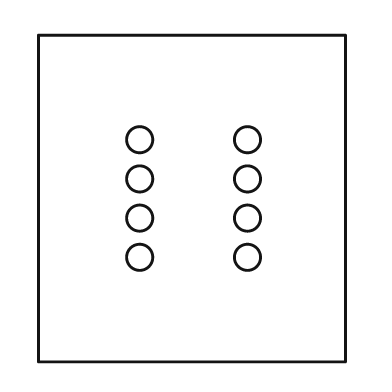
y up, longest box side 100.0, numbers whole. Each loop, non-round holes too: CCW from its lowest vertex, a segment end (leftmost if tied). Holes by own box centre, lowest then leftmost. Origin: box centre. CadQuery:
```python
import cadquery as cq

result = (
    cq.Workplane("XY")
    .moveTo(-47.0, -50.0)
    .lineTo(47.0, -50.0)
    .lineTo(47.0, 50.0)
    .lineTo(-47.0, 50.0)
    .close()
    .moveTo(-16.0, -18.0)
    .circle(4.0)
    .moveTo(17.0, -18.0)
    .circle(4.0)
    .moveTo(-16.0, -6.0)
    .circle(4.0)
    .moveTo(17.0, -6.0)
    .circle(4.0)
    .moveTo(-16.0, 6.0)
    .circle(4.0)
    .moveTo(17.0, 6.0)
    .circle(4.0)
    .moveTo(-16.0, 18.0)
    .circle(4.0)
    .moveTo(17.0, 18.0)
    .circle(4.0)
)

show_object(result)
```